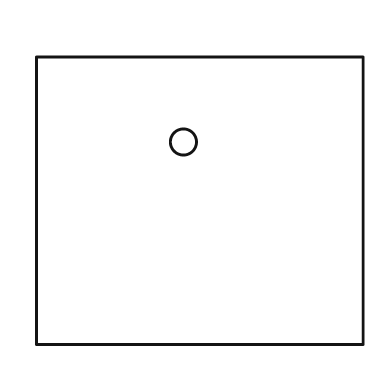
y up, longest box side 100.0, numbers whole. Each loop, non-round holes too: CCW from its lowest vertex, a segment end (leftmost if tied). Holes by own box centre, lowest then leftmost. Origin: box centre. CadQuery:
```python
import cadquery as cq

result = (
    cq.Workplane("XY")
    .moveTo(-50.0, -44.0)
    .lineTo(50.0, -44.0)
    .lineTo(50.0, 44.0)
    .lineTo(-50.0, 44.0)
    .close()
    .moveTo(-5.0, 18.0)
    .circle(4.0)
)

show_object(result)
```